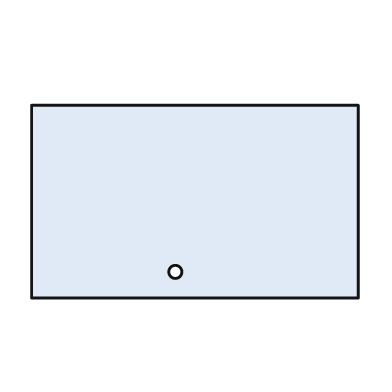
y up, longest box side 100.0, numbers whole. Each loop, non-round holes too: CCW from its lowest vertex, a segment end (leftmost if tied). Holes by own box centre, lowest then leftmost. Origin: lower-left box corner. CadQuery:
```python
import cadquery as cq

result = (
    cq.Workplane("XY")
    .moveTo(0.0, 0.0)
    .lineTo(100.0, 0.0)
    .lineTo(100.0, 59.0)
    .lineTo(0.0, 59.0)
    .close()
    .moveTo(44.0, 8.0)
    .circle(2.0)
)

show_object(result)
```